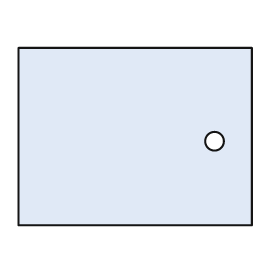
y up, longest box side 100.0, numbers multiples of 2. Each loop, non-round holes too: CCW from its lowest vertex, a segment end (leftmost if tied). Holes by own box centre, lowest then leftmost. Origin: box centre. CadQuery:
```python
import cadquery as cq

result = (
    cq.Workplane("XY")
    .moveTo(-50.0, -38.0)
    .lineTo(50.0, -38.0)
    .lineTo(50.0, 38.0)
    .lineTo(-50.0, 38.0)
    .close()
    .moveTo(34.0, -2.0)
    .circle(4.0)
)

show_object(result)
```